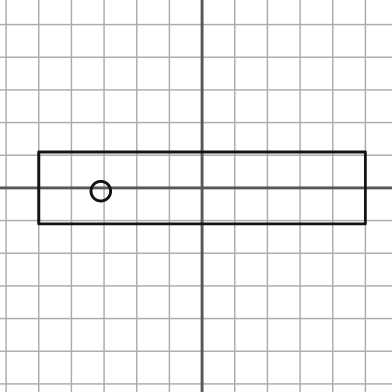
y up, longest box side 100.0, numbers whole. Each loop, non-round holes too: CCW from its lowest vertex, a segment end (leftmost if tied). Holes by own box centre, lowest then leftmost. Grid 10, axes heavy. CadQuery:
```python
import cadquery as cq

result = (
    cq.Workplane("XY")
    .moveTo(-50.0, -11.0)
    .lineTo(50.0, -11.0)
    .lineTo(50.0, 11.0)
    .lineTo(-50.0, 11.0)
    .close()
    .moveTo(-31.0, -1.0)
    .circle(3.0)
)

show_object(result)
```